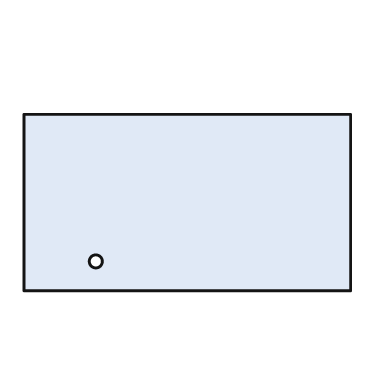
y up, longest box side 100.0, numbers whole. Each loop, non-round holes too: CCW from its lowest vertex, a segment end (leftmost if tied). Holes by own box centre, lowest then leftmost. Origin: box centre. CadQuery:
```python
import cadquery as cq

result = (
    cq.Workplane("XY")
    .moveTo(-50.0, -27.0)
    .lineTo(50.0, -27.0)
    .lineTo(50.0, 27.0)
    .lineTo(-50.0, 27.0)
    .close()
    .moveTo(-28.0, -18.0)
    .circle(2.0)
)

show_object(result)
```